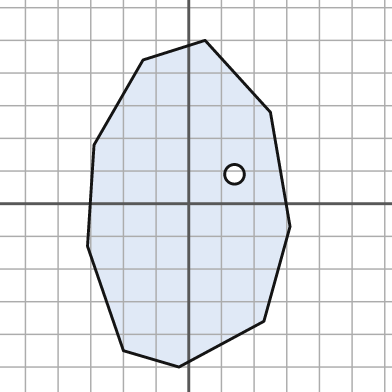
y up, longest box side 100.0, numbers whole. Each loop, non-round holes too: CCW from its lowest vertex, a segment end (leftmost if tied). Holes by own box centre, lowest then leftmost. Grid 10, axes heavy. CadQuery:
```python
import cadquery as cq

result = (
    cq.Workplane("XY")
    .moveTo(-3.0, -50.0)
    .lineTo(23.0, -36.0)
    .lineTo(31.0, -7.0)
    .lineTo(25.0, 28.0)
    .lineTo(5.0, 50.0)
    .lineTo(-14.0, 44.0)
    .lineTo(-29.0, 18.0)
    .lineTo(-31.0, -13.0)
    .lineTo(-20.0, -45.0)
    .close()
    .moveTo(14.0, 9.0)
    .circle(3.0)
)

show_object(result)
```